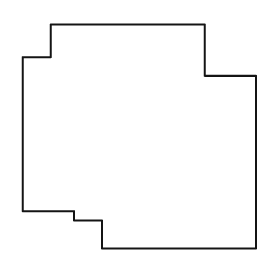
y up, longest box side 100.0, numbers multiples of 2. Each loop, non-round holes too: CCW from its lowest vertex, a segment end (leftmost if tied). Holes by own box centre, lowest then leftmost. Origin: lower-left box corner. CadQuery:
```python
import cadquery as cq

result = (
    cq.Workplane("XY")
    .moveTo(34.0, 0.0)
    .lineTo(100.0, 0.0)
    .lineTo(100.0, 74.0)
    .lineTo(78.0, 74.0)
    .lineTo(78.0, 96.0)
    .lineTo(12.0, 96.0)
    .lineTo(12.0, 82.0)
    .lineTo(0.0, 82.0)
    .lineTo(0.0, 16.0)
    .lineTo(22.0, 16.0)
    .lineTo(22.0, 12.0)
    .lineTo(34.0, 12.0)
    .close()
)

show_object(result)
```